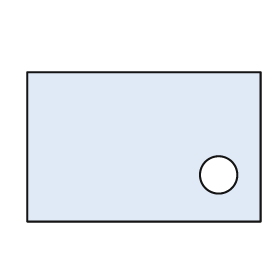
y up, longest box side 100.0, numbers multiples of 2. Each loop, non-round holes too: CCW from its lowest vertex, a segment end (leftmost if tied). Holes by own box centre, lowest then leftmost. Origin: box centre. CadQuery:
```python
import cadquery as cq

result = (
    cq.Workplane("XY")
    .moveTo(-50.0, -32.0)
    .lineTo(50.0, -32.0)
    .lineTo(50.0, 32.0)
    .lineTo(-50.0, 32.0)
    .close()
    .moveTo(32.0, -12.0)
    .circle(8.0)
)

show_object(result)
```